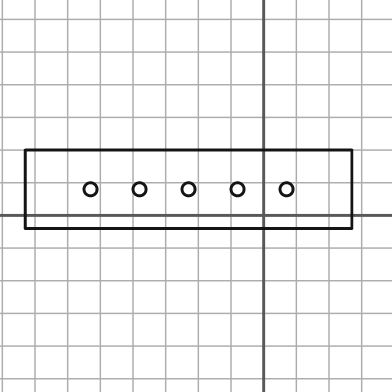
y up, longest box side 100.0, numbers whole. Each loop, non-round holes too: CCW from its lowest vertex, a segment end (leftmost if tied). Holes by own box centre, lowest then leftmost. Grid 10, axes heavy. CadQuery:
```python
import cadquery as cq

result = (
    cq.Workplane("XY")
    .moveTo(-73.0, -4.0)
    .lineTo(27.0, -4.0)
    .lineTo(27.0, 20.0)
    .lineTo(-73.0, 20.0)
    .close()
    .moveTo(-53.0, 8.0)
    .circle(2.0)
    .moveTo(-38.0, 8.0)
    .circle(2.0)
    .moveTo(-23.0, 8.0)
    .circle(2.0)
    .moveTo(-8.0, 8.0)
    .circle(2.0)
    .moveTo(7.0, 8.0)
    .circle(2.0)
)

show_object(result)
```